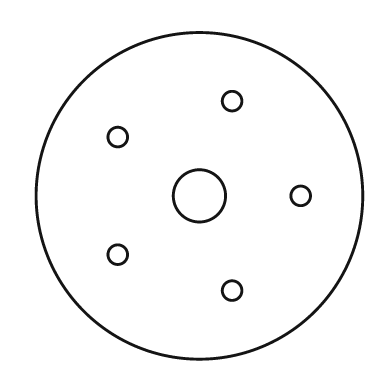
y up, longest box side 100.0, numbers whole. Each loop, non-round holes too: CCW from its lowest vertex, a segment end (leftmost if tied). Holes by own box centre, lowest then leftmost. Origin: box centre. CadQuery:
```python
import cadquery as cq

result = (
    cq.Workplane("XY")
    .moveTo(0.0, 0.0)
    .circle(50.0)
    .moveTo(10.0, -29.0)
    .circle(3.0)
    .moveTo(-25.0, -18.0)
    .circle(3.0)
    .moveTo(0.0, 0.0)
    .circle(8.0)
    .moveTo(31.0, 0.0)
    .circle(3.0)
    .moveTo(-25.0, 18.0)
    .circle(3.0)
    .moveTo(10.0, 29.0)
    .circle(3.0)
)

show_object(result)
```